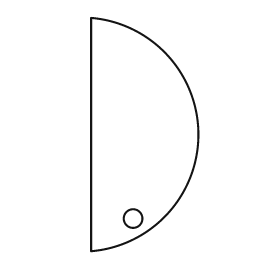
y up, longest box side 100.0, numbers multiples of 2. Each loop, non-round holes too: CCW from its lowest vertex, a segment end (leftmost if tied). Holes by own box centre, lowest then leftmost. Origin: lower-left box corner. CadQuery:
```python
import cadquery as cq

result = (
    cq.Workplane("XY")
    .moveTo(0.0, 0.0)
    .threePointArc((46.0, 50.0), (0.0, 100.0))
    .close()
    .moveTo(18.0, 14.0)
    .circle(4.0)
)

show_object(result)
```